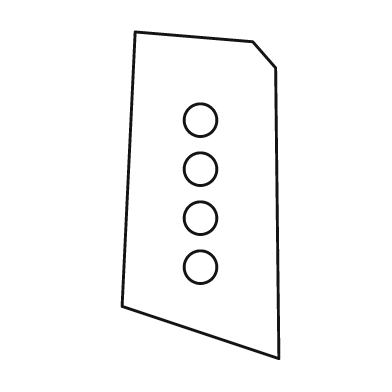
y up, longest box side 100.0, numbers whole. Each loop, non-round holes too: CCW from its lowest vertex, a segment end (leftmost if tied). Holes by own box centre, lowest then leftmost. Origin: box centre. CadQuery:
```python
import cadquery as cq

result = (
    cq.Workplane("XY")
    .moveTo(24.0, -50.0)
    .lineTo(23.0, 39.0)
    .lineTo(16.0, 47.0)
    .lineTo(-20.0, 50.0)
    .lineTo(-24.0, -34.0)
    .close()
    .moveTo(0.0, -22.0)
    .circle(5.0)
    .moveTo(0.0, -7.0)
    .circle(5.0)
    .moveTo(0.0, 8.0)
    .circle(5.0)
    .moveTo(0.0, 23.0)
    .circle(5.0)
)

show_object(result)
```